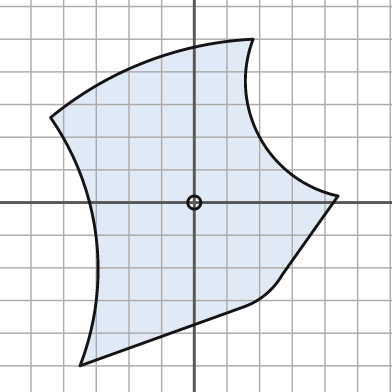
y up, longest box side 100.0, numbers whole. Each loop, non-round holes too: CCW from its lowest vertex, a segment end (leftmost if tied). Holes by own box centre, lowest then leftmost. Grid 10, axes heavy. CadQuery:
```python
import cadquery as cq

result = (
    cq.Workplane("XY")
    .moveTo(-35.0, -50.0)
    .lineTo(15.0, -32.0)
    .threePointArc((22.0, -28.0), (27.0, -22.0))
    .lineTo(44.0, 2.0)
    .threePointArc((20.0, 20.0), (18.0, 50.0))
    .threePointArc((-15.0, 43.0), (-44.0, 26.0))
    .threePointArc((-30.0, -11.0), (-35.0, -50.0))
    .close()
    .moveTo(0.0, 0.0)
    .circle(2.0)
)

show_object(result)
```